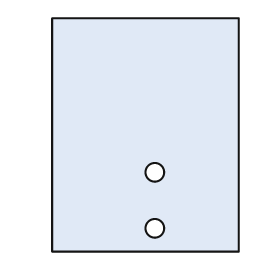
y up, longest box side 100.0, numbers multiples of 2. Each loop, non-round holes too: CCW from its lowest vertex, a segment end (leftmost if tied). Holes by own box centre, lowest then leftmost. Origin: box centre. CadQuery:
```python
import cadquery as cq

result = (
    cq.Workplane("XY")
    .moveTo(-40.0, -50.0)
    .lineTo(40.0, -50.0)
    .lineTo(40.0, 50.0)
    .lineTo(-40.0, 50.0)
    .close()
    .moveTo(4.0, -40.0)
    .circle(4.0)
    .moveTo(4.0, -16.0)
    .circle(4.0)
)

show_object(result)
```